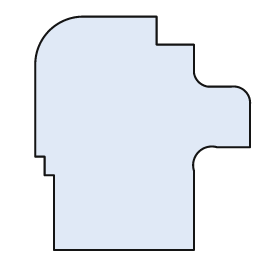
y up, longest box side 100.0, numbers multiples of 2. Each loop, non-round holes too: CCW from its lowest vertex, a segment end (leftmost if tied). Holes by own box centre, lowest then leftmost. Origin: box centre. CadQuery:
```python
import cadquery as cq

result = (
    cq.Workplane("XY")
    .moveTo(-38.0, -50.0)
    .lineTo(22.0, -50.0)
    .lineTo(22.0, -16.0)
    .threePointArc((24.0, -8.0), (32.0, -6.0))
    .lineTo(46.0, -6.0)
    .lineTo(46.0, 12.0)
    .threePointArc((44.0, 18.0), (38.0, 20.0))
    .lineTo(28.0, 20.0)
    .threePointArc((24.0, 22.0), (22.0, 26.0))
    .lineTo(22.0, 38.0)
    .lineTo(6.0, 38.0)
    .lineTo(6.0, 50.0)
    .lineTo(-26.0, 50.0)
    .threePointArc((-40.0, 44.0), (-46.0, 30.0))
    .lineTo(-46.0, -10.0)
    .lineTo(-42.0, -10.0)
    .lineTo(-42.0, -18.0)
    .lineTo(-38.0, -18.0)
    .close()
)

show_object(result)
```